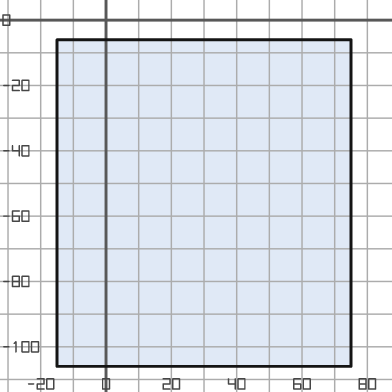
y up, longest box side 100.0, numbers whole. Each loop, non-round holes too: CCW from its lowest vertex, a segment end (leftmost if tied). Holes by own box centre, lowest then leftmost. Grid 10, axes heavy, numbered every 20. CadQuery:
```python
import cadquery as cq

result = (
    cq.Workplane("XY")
    .moveTo(-15.0, -106.0)
    .lineTo(75.0, -106.0)
    .lineTo(75.0, -6.0)
    .lineTo(-15.0, -6.0)
    .close()
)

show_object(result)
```